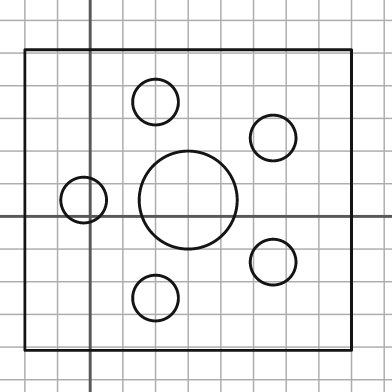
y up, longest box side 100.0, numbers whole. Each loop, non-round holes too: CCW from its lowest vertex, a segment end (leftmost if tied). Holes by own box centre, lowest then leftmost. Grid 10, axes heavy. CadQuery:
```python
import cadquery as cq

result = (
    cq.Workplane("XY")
    .moveTo(-20.0, -41.0)
    .lineTo(80.0, -41.0)
    .lineTo(80.0, 51.0)
    .lineTo(-20.0, 51.0)
    .close()
    .moveTo(20.0, -25.0)
    .circle(7.0)
    .moveTo(56.0, -14.0)
    .circle(7.0)
    .moveTo(-2.0, 5.0)
    .circle(7.0)
    .moveTo(30.0, 5.0)
    .circle(15.0)
    .moveTo(56.0, 24.0)
    .circle(7.0)
    .moveTo(20.0, 35.0)
    .circle(7.0)
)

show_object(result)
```